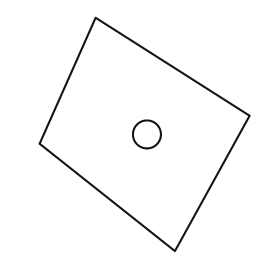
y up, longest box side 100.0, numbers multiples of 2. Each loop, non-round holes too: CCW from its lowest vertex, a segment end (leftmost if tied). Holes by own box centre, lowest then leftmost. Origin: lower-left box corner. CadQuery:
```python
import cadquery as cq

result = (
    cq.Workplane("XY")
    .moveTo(58.0, 0.0)
    .lineTo(90.0, 58.0)
    .lineTo(24.0, 100.0)
    .lineTo(0.0, 46.0)
    .close()
    .moveTo(46.0, 50.0)
    .circle(6.0)
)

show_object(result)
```